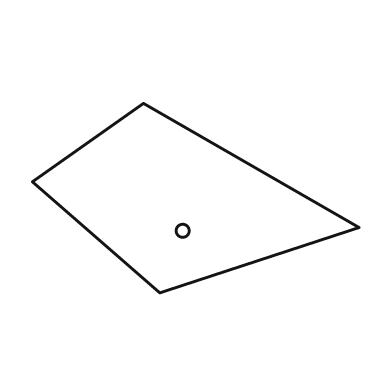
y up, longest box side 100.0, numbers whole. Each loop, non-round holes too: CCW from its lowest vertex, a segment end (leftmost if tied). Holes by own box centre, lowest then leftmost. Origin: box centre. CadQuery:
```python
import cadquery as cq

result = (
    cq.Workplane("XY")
    .moveTo(-11.0, -29.0)
    .lineTo(50.0, -9.0)
    .lineTo(-16.0, 29.0)
    .lineTo(-50.0, 5.0)
    .close()
    .moveTo(-4.0, -10.0)
    .circle(2.0)
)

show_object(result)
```